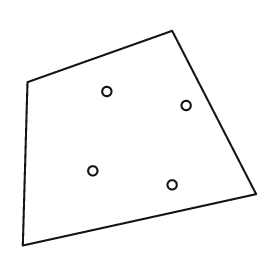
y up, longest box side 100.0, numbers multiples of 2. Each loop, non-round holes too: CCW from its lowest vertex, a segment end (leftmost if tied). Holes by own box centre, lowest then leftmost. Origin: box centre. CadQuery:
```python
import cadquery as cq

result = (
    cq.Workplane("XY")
    .moveTo(-50.0, -46.0)
    .lineTo(50.0, -24.0)
    .lineTo(14.0, 46.0)
    .lineTo(-48.0, 24.0)
    .close()
    .moveTo(14.0, -20.0)
    .circle(2.0)
    .moveTo(-20.0, -14.0)
    .circle(2.0)
    .moveTo(20.0, 14.0)
    .circle(2.0)
    .moveTo(-14.0, 20.0)
    .circle(2.0)
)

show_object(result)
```